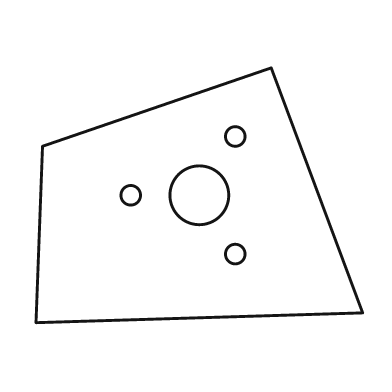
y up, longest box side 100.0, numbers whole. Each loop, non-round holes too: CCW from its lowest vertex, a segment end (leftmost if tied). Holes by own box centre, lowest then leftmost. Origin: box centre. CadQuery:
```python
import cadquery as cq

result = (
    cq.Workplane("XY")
    .moveTo(-50.0, -39.0)
    .lineTo(50.0, -36.0)
    .lineTo(22.0, 39.0)
    .lineTo(-48.0, 15.0)
    .close()
    .moveTo(11.0, -18.0)
    .circle(3.0)
    .moveTo(-21.0, 0.0)
    .circle(3.0)
    .moveTo(0.0, 0.0)
    .circle(9.0)
    .moveTo(11.0, 18.0)
    .circle(3.0)
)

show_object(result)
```